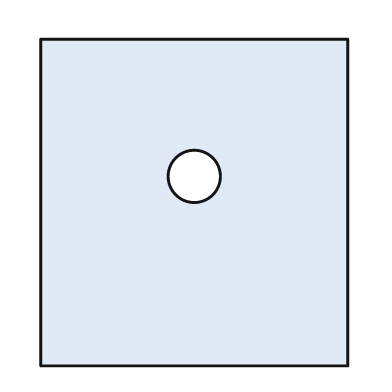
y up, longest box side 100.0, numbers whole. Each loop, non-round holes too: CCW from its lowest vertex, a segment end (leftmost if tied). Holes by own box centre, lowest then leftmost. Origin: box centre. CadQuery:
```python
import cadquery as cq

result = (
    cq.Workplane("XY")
    .moveTo(-47.0, -50.0)
    .lineTo(47.0, -50.0)
    .lineTo(47.0, 50.0)
    .lineTo(-47.0, 50.0)
    .close()
    .moveTo(0.0, 8.0)
    .circle(8.0)
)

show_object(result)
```